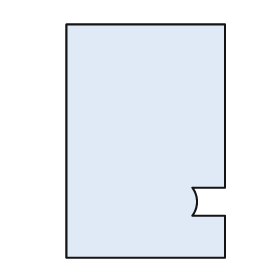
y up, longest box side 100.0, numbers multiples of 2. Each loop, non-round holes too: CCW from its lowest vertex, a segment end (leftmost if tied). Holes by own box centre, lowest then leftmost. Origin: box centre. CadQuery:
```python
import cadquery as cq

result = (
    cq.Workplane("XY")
    .moveTo(-34.0, -50.0)
    .lineTo(34.0, -50.0)
    .lineTo(34.0, -32.0)
    .lineTo(20.0, -32.0)
    .threePointArc((22.0, -26.0), (20.0, -20.0))
    .lineTo(34.0, -20.0)
    .lineTo(34.0, 50.0)
    .lineTo(-34.0, 50.0)
    .close()
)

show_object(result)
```